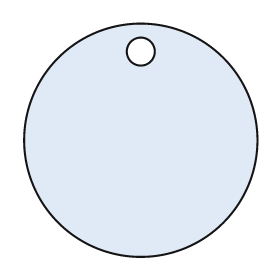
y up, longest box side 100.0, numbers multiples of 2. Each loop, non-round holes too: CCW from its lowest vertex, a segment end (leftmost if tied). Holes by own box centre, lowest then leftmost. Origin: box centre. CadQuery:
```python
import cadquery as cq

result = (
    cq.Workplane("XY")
    .moveTo(0.0, 0.0)
    .circle(50.0)
    .moveTo(0.0, 38.0)
    .circle(6.0)
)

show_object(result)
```